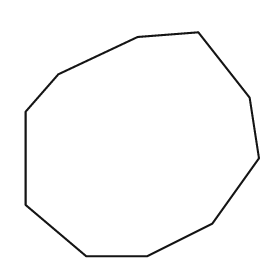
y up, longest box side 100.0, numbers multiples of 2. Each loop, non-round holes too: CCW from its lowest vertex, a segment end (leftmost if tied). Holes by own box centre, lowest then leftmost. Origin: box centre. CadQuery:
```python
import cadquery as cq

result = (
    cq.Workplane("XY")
    .moveTo(-24.0, -48.0)
    .lineTo(2.0, -48.0)
    .lineTo(30.0, -34.0)
    .lineTo(50.0, -6.0)
    .lineTo(46.0, 20.0)
    .lineTo(24.0, 48.0)
    .lineTo(-2.0, 46.0)
    .lineTo(-36.0, 30.0)
    .lineTo(-50.0, 14.0)
    .lineTo(-50.0, -26.0)
    .close()
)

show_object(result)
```